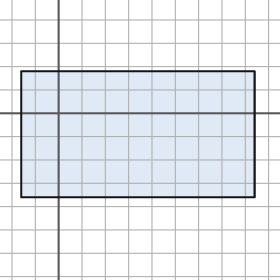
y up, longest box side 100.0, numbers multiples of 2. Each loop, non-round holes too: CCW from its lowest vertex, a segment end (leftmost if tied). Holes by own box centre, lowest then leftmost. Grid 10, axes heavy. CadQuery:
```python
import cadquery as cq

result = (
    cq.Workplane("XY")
    .moveTo(-16.0, -36.0)
    .lineTo(84.0, -36.0)
    .lineTo(84.0, 18.0)
    .lineTo(-16.0, 18.0)
    .close()
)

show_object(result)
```